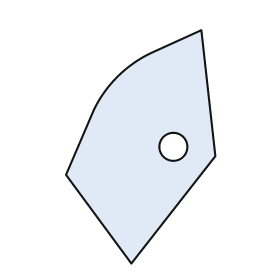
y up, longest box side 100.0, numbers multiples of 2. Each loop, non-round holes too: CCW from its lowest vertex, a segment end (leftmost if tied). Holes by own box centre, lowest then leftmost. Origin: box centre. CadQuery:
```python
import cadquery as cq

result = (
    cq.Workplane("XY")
    .moveTo(-4.0, -50.0)
    .lineTo(32.0, -4.0)
    .lineTo(26.0, 50.0)
    .lineTo(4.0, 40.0)
    .threePointArc((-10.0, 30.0), (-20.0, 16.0))
    .lineTo(-32.0, -12.0)
    .close()
    .moveTo(14.0, 0.0)
    .circle(6.0)
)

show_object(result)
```